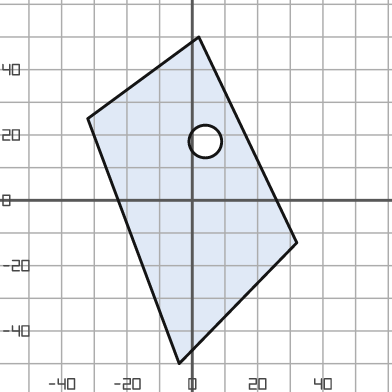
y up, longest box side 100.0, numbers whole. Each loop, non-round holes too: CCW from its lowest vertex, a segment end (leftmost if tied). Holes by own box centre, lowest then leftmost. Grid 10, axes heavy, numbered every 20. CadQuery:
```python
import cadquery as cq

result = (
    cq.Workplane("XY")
    .moveTo(-4.0, -50.0)
    .lineTo(32.0, -13.0)
    .lineTo(2.0, 50.0)
    .lineTo(-32.0, 25.0)
    .close()
    .moveTo(4.0, 18.0)
    .circle(5.0)
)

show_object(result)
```